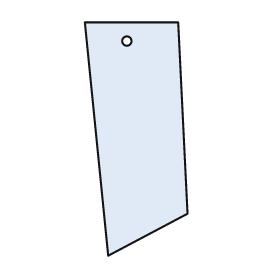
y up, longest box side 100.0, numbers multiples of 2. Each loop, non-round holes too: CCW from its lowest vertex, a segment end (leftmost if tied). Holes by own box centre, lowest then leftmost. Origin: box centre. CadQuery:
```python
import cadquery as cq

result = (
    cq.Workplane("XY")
    .moveTo(-12.0, -50.0)
    .lineTo(22.0, -32.0)
    .lineTo(18.0, 50.0)
    .lineTo(-22.0, 50.0)
    .close()
    .moveTo(-4.0, 42.0)
    .circle(2.0)
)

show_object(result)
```